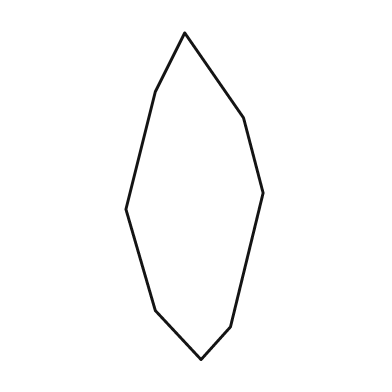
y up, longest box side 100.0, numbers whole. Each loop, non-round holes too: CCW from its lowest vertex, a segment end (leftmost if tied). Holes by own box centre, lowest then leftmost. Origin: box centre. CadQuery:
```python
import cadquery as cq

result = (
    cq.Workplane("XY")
    .moveTo(2.0, -50.0)
    .lineTo(11.0, -40.0)
    .lineTo(21.0, 1.0)
    .lineTo(15.0, 24.0)
    .lineTo(-3.0, 50.0)
    .lineTo(-12.0, 32.0)
    .lineTo(-21.0, -4.0)
    .lineTo(-12.0, -35.0)
    .close()
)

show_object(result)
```